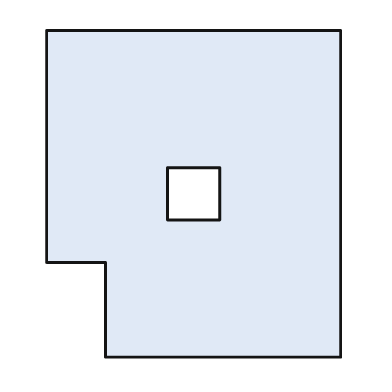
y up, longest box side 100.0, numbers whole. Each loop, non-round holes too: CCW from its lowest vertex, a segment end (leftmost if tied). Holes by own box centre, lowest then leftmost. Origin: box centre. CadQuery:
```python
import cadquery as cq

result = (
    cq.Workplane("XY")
    .moveTo(-27.0, -50.0)
    .lineTo(45.0, -50.0)
    .lineTo(45.0, 50.0)
    .lineTo(-45.0, 50.0)
    .lineTo(-45.0, -21.0)
    .lineTo(-27.0, -21.0)
    .close()
    .moveTo(-8.0, -8.0)
    .lineTo(8.0, -8.0)
    .lineTo(8.0, 8.0)
    .lineTo(-8.0, 8.0)
    .close()
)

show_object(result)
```